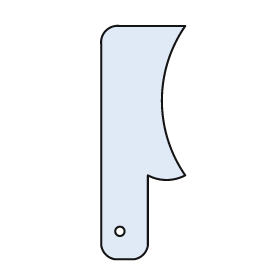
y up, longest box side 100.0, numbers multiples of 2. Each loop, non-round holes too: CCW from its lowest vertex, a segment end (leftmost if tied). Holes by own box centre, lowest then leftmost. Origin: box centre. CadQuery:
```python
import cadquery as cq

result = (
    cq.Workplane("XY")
    .moveTo(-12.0, -50.0)
    .lineTo(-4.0, -50.0)
    .threePointArc((0.0, -48.0), (2.0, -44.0))
    .lineTo(2.0, -14.0)
    .threePointArc((10.0, -16.0), (18.0, -14.0))
    .threePointArc((8.0, 18.0), (18.0, 50.0))
    .lineTo(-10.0, 50.0)
    .threePointArc((-16.0, 48.0), (-18.0, 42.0))
    .lineTo(-18.0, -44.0)
    .threePointArc((-16.0, -48.0), (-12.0, -50.0))
    .close()
    .moveTo(-10.0, -38.0)
    .circle(2.0)
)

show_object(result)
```